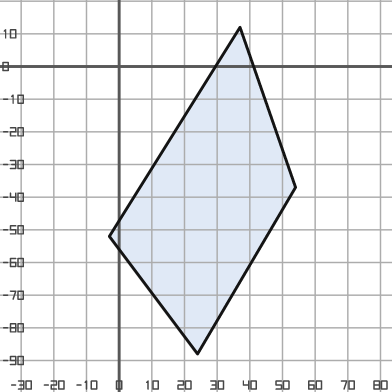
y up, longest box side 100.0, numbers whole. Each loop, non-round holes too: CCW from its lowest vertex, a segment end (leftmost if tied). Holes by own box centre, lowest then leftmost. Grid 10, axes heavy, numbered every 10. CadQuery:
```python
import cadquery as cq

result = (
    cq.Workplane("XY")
    .moveTo(24.0, -88.0)
    .lineTo(54.0, -37.0)
    .lineTo(37.0, 12.0)
    .lineTo(-3.0, -52.0)
    .close()
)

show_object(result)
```